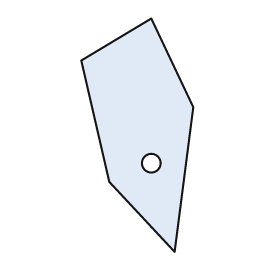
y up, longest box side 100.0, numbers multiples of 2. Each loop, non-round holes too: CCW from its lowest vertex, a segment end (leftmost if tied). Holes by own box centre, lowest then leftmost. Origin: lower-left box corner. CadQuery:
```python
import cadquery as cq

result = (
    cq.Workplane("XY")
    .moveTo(40.0, 0.0)
    .lineTo(48.0, 62.0)
    .lineTo(30.0, 100.0)
    .lineTo(0.0, 82.0)
    .lineTo(12.0, 30.0)
    .close()
    .moveTo(30.0, 38.0)
    .circle(4.0)
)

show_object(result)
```